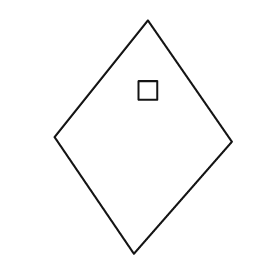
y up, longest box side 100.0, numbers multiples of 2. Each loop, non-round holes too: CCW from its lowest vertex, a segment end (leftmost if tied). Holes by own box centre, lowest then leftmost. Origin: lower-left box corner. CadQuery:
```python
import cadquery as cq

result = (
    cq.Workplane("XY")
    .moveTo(34.0, 0.0)
    .lineTo(76.0, 48.0)
    .lineTo(40.0, 100.0)
    .lineTo(0.0, 50.0)
    .close()
    .moveTo(36.0, 66.0)
    .lineTo(44.0, 66.0)
    .lineTo(44.0, 74.0)
    .lineTo(36.0, 74.0)
    .close()
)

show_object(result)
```